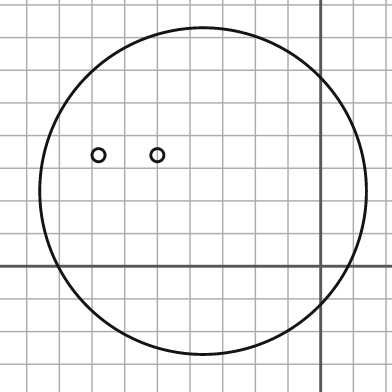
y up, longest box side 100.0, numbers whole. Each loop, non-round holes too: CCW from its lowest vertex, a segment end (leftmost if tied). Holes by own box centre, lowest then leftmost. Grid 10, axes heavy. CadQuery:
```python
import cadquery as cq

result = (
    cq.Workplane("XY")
    .moveTo(-36.0, 23.0)
    .circle(50.0)
    .moveTo(-68.0, 34.0)
    .circle(2.0)
    .moveTo(-50.0, 34.0)
    .circle(2.0)
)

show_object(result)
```